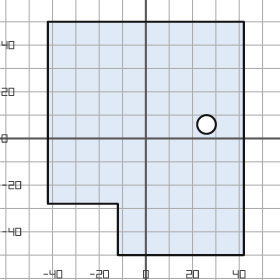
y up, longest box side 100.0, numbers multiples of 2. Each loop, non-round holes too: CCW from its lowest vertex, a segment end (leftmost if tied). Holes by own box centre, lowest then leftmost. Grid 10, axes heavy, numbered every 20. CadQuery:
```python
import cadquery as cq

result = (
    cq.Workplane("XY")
    .moveTo(-12.0, -50.0)
    .lineTo(42.0, -50.0)
    .lineTo(42.0, 50.0)
    .lineTo(-42.0, 50.0)
    .lineTo(-42.0, -28.0)
    .lineTo(-12.0, -28.0)
    .close()
    .moveTo(26.0, 6.0)
    .circle(4.0)
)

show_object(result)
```